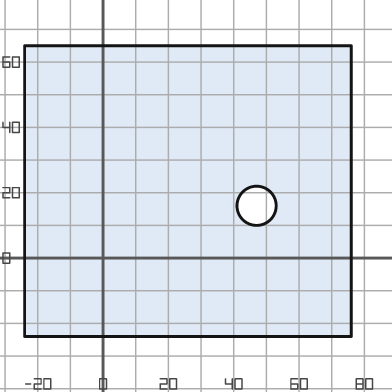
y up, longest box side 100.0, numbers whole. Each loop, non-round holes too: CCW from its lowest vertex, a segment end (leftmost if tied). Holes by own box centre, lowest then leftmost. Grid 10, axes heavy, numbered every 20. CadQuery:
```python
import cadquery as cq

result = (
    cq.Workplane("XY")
    .moveTo(-24.0, -24.0)
    .lineTo(76.0, -24.0)
    .lineTo(76.0, 65.0)
    .lineTo(-24.0, 65.0)
    .close()
    .moveTo(47.0, 16.0)
    .circle(6.0)
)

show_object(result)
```